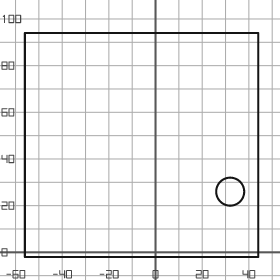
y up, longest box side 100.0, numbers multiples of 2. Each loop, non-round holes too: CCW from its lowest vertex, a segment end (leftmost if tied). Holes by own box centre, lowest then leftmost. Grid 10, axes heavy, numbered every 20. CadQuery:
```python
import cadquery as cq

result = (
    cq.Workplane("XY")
    .moveTo(-56.0, -2.0)
    .lineTo(44.0, -2.0)
    .lineTo(44.0, 94.0)
    .lineTo(-56.0, 94.0)
    .close()
    .moveTo(32.0, 26.0)
    .circle(6.0)
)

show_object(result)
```